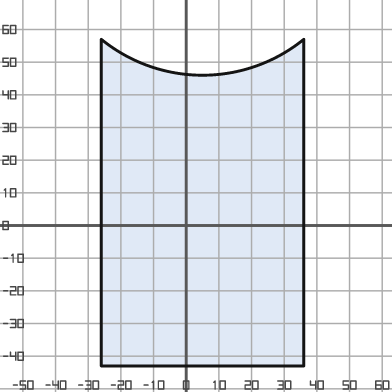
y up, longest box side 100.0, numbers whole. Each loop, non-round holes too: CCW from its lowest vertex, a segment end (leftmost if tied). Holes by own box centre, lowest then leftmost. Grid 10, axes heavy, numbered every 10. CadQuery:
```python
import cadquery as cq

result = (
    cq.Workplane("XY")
    .moveTo(-26.0, -43.0)
    .lineTo(36.0, -43.0)
    .lineTo(36.0, 57.0)
    .threePointArc((5.0, 46.0), (-26.0, 57.0))
    .close()
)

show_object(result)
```